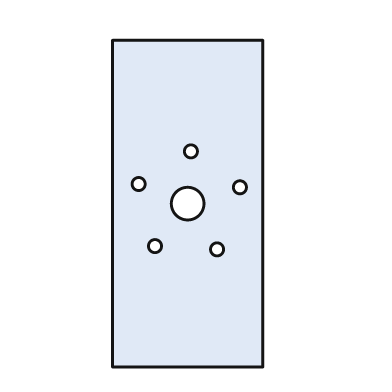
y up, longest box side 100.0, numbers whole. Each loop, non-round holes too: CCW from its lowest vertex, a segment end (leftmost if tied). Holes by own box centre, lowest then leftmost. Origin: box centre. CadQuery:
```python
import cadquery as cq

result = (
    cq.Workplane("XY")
    .moveTo(-23.0, -50.0)
    .lineTo(23.0, -50.0)
    .lineTo(23.0, 50.0)
    .lineTo(-23.0, 50.0)
    .close()
    .moveTo(9.0, -14.0)
    .circle(2.0)
    .moveTo(-10.0, -13.0)
    .circle(2.0)
    .moveTo(0.0, 0.0)
    .circle(5.0)
    .moveTo(16.0, 5.0)
    .circle(2.0)
    .moveTo(-15.0, 6.0)
    .circle(2.0)
    .moveTo(1.0, 16.0)
    .circle(2.0)
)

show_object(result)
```